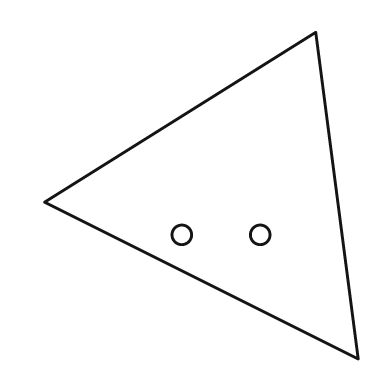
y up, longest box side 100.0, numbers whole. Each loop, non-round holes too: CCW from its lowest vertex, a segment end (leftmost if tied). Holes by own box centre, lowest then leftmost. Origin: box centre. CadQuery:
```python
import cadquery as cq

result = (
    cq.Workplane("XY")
    .moveTo(48.0, -50.0)
    .lineTo(35.0, 50.0)
    .lineTo(-48.0, -2.0)
    .close()
    .moveTo(-6.0, -12.0)
    .circle(3.0)
    .moveTo(18.0, -12.0)
    .circle(3.0)
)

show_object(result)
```